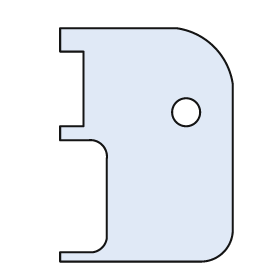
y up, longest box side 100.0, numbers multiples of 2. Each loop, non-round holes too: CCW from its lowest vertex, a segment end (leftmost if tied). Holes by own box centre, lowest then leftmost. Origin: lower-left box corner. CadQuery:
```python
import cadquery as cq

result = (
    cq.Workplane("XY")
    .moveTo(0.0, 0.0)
    .lineTo(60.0, 0.0)
    .threePointArc((70.0, 4.0), (74.0, 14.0))
    .lineTo(74.0, 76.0)
    .threePointArc((66.0, 92.0), (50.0, 100.0))
    .lineTo(0.0, 100.0)
    .lineTo(0.0, 90.0)
    .lineTo(10.0, 90.0)
    .lineTo(10.0, 58.0)
    .lineTo(0.0, 58.0)
    .lineTo(0.0, 52.0)
    .lineTo(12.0, 52.0)
    .threePointArc((18.0, 50.0), (20.0, 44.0))
    .lineTo(20.0, 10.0)
    .threePointArc((18.0, 6.0), (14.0, 4.0))
    .lineTo(0.0, 4.0)
    .close()
    .moveTo(54.0, 64.0)
    .circle(6.0)
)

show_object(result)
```